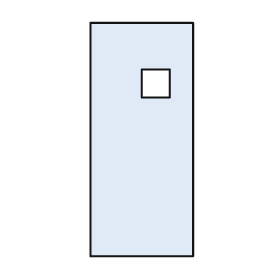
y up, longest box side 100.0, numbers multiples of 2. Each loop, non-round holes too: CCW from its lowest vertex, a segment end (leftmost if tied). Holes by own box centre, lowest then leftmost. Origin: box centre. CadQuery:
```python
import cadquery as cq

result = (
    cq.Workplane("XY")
    .moveTo(-22.0, -50.0)
    .lineTo(22.0, -50.0)
    .lineTo(22.0, 50.0)
    .lineTo(-22.0, 50.0)
    .close()
    .moveTo(0.0, 18.0)
    .lineTo(12.0, 18.0)
    .lineTo(12.0, 30.0)
    .lineTo(0.0, 30.0)
    .close()
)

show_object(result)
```